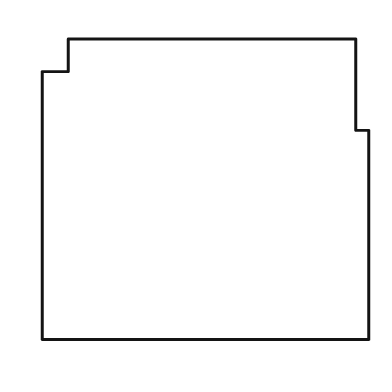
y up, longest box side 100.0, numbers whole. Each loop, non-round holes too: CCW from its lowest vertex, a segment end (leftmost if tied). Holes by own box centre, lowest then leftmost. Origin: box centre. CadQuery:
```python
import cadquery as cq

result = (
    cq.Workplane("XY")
    .moveTo(-50.0, -46.0)
    .lineTo(50.0, -46.0)
    .lineTo(50.0, 18.0)
    .lineTo(46.0, 18.0)
    .lineTo(46.0, 46.0)
    .lineTo(-42.0, 46.0)
    .lineTo(-42.0, 36.0)
    .lineTo(-50.0, 36.0)
    .close()
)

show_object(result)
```